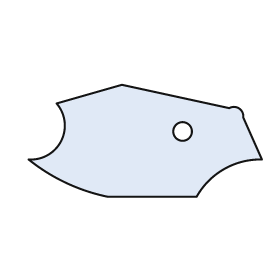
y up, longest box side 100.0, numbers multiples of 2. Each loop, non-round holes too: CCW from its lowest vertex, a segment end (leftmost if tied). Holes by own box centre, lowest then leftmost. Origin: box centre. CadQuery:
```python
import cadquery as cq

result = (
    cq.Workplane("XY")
    .moveTo(-16.0, -24.0)
    .lineTo(22.0, -24.0)
    .threePointArc((34.0, -12.0), (50.0, -8.0))
    .lineTo(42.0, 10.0)
    .threePointArc((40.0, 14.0), (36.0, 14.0))
    .lineTo(-10.0, 24.0)
    .lineTo(-38.0, 16.0)
    .threePointArc((-36.0, 0.0), (-50.0, -8.0))
    .threePointArc((-34.0, -18.0), (-16.0, -24.0))
    .close()
    .moveTo(16.0, 4.0)
    .circle(4.0)
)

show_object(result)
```